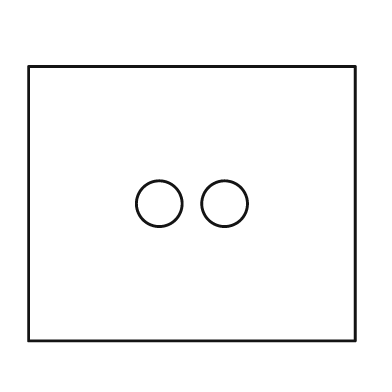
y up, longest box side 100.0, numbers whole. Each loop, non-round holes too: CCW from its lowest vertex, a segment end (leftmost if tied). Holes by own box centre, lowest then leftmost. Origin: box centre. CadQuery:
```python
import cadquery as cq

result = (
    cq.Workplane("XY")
    .moveTo(-50.0, -42.0)
    .lineTo(50.0, -42.0)
    .lineTo(50.0, 42.0)
    .lineTo(-50.0, 42.0)
    .close()
    .moveTo(-10.0, 0.0)
    .circle(7.0)
    .moveTo(10.0, 0.0)
    .circle(7.0)
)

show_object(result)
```